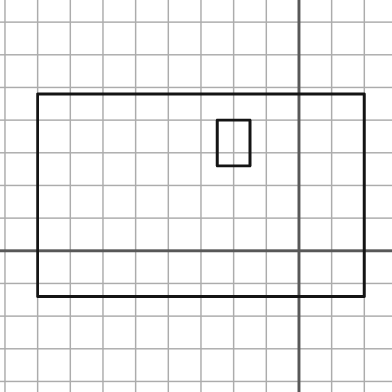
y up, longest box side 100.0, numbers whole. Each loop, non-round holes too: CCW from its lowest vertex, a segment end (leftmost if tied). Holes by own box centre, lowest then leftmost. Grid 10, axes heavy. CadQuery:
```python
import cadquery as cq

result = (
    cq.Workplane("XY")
    .moveTo(-80.0, -14.0)
    .lineTo(20.0, -14.0)
    .lineTo(20.0, 48.0)
    .lineTo(-80.0, 48.0)
    .close()
    .moveTo(-25.0, 26.0)
    .lineTo(-15.0, 26.0)
    .lineTo(-15.0, 40.0)
    .lineTo(-25.0, 40.0)
    .close()
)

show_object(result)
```